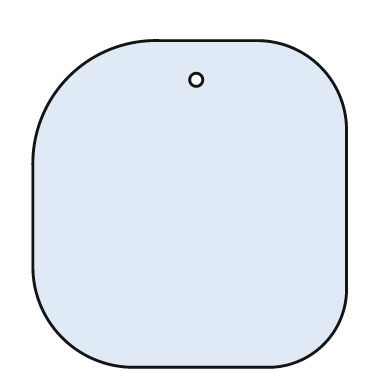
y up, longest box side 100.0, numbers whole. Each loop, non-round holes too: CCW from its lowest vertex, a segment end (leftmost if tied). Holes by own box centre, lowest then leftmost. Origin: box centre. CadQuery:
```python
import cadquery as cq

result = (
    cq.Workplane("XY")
    .moveTo(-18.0, -50.0)
    .lineTo(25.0, -50.0)
    .threePointArc((41.0, -43.0), (48.0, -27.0))
    .lineTo(48.0, 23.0)
    .threePointArc((40.0, 42.0), (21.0, 50.0))
    .lineTo(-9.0, 50.0)
    .threePointArc((-37.0, 39.0), (-48.0, 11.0))
    .lineTo(-48.0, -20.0)
    .threePointArc((-39.0, -41.0), (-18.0, -50.0))
    .close()
    .moveTo(2.0, 38.0)
    .circle(2.0)
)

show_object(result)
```